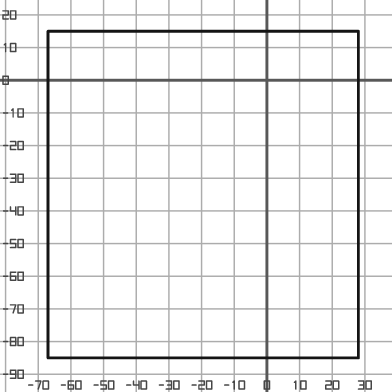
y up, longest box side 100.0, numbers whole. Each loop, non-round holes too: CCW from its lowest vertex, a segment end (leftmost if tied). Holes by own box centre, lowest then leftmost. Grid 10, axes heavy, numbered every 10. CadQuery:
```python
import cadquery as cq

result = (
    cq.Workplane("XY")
    .moveTo(-67.0, -85.0)
    .lineTo(28.0, -85.0)
    .lineTo(28.0, 15.0)
    .lineTo(-67.0, 15.0)
    .close()
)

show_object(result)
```